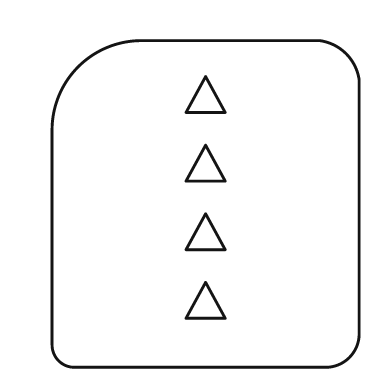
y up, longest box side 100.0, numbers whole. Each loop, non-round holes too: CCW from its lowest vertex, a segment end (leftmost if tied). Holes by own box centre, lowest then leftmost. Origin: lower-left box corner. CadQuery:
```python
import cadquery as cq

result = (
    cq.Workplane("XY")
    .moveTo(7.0, 0.0)
    .lineTo(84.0, 0.0)
    .threePointArc((91.0, 3.0), (94.0, 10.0))
    .lineTo(94.0, 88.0)
    .threePointArc((90.0, 96.0), (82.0, 100.0))
    .lineTo(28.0, 100.0)
    .threePointArc((8.0, 92.0), (0.0, 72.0))
    .lineTo(0.0, 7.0)
    .threePointArc((2.0, 2.0), (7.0, 0.0))
    .close()
    .moveTo(41.0, 15.0)
    .lineTo(53.0, 15.0)
    .lineTo(47.0, 26.0)
    .close()
    .moveTo(41.0, 36.0)
    .lineTo(53.0, 36.0)
    .lineTo(47.0, 47.0)
    .close()
    .moveTo(41.0, 57.0)
    .lineTo(53.0, 57.0)
    .lineTo(47.0, 68.0)
    .close()
    .moveTo(41.0, 78.0)
    .lineTo(53.0, 78.0)
    .lineTo(47.0, 89.0)
    .close()
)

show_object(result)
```